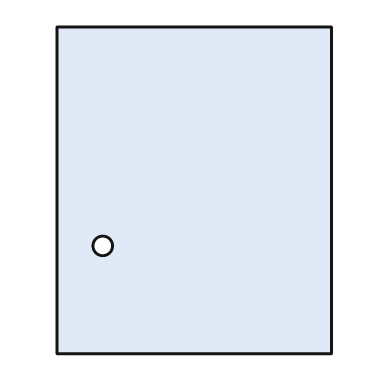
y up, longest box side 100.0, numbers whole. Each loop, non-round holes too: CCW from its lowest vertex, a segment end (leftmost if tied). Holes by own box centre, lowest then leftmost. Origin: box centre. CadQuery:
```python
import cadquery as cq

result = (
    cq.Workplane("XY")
    .moveTo(-42.0, -50.0)
    .lineTo(42.0, -50.0)
    .lineTo(42.0, 50.0)
    .lineTo(-42.0, 50.0)
    .close()
    .moveTo(-28.0, -17.0)
    .circle(3.0)
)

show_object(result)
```